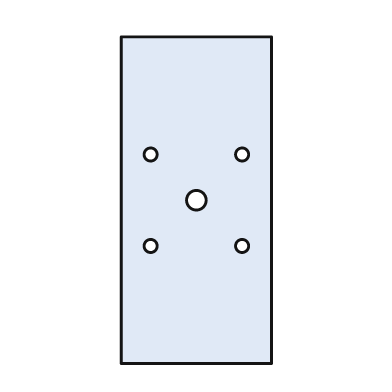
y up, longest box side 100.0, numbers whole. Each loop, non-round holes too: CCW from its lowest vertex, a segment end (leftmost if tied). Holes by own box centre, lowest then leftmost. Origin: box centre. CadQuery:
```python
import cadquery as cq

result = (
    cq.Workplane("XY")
    .moveTo(-23.0, -50.0)
    .lineTo(23.0, -50.0)
    .lineTo(23.0, 50.0)
    .lineTo(-23.0, 50.0)
    .close()
    .moveTo(-14.0, -14.0)
    .circle(2.0)
    .moveTo(14.0, -14.0)
    .circle(2.0)
    .moveTo(0.0, 0.0)
    .circle(3.0)
    .moveTo(-14.0, 14.0)
    .circle(2.0)
    .moveTo(14.0, 14.0)
    .circle(2.0)
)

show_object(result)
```